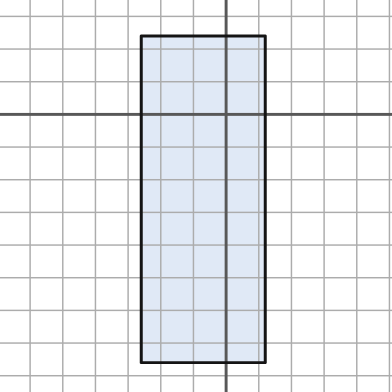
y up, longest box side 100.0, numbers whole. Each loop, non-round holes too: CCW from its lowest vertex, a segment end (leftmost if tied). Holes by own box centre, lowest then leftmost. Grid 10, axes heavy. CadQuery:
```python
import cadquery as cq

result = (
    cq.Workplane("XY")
    .moveTo(-26.0, -76.0)
    .lineTo(12.0, -76.0)
    .lineTo(12.0, 24.0)
    .lineTo(-26.0, 24.0)
    .close()
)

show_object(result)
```